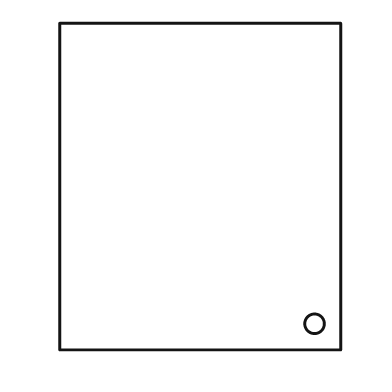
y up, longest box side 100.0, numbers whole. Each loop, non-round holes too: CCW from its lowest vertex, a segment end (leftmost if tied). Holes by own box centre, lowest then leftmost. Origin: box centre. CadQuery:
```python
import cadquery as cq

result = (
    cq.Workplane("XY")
    .moveTo(-43.0, -50.0)
    .lineTo(43.0, -50.0)
    .lineTo(43.0, 50.0)
    .lineTo(-43.0, 50.0)
    .close()
    .moveTo(35.0, -42.0)
    .circle(3.0)
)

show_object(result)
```